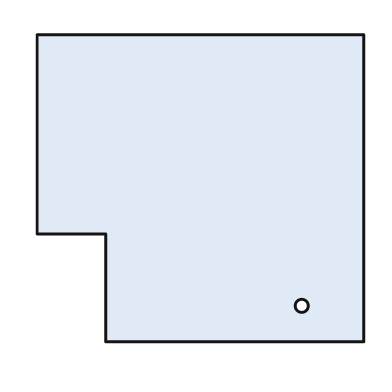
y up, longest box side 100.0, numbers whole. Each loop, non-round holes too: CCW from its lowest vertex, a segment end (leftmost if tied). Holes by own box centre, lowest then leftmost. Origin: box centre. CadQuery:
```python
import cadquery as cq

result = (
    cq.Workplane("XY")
    .moveTo(-29.0, -47.0)
    .lineTo(50.0, -47.0)
    .lineTo(50.0, 47.0)
    .lineTo(-50.0, 47.0)
    .lineTo(-50.0, -14.0)
    .lineTo(-29.0, -14.0)
    .close()
    .moveTo(31.0, -36.0)
    .circle(2.0)
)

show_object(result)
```